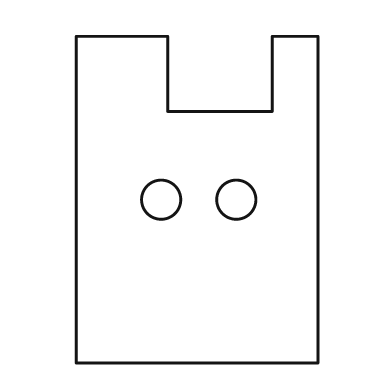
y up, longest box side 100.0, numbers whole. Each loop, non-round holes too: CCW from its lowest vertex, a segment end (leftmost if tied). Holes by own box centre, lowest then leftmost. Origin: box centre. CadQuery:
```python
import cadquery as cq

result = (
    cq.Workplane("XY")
    .moveTo(-37.0, -50.0)
    .lineTo(37.0, -50.0)
    .lineTo(37.0, 50.0)
    .lineTo(23.0, 50.0)
    .lineTo(23.0, 27.0)
    .lineTo(-9.0, 27.0)
    .lineTo(-9.0, 50.0)
    .lineTo(-37.0, 50.0)
    .close()
    .moveTo(-11.0, 0.0)
    .circle(6.0)
    .moveTo(12.0, 0.0)
    .circle(6.0)
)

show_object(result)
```